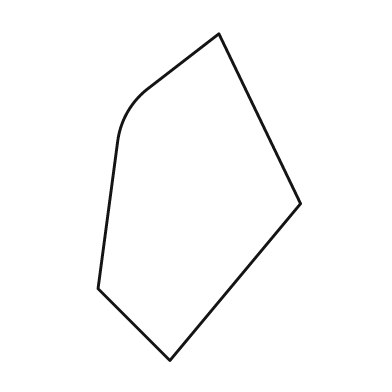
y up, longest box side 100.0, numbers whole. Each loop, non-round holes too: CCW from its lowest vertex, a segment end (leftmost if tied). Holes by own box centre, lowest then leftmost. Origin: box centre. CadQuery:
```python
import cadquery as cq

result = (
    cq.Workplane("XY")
    .moveTo(-9.0, -50.0)
    .lineTo(31.0, -2.0)
    .lineTo(6.0, 50.0)
    .lineTo(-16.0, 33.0)
    .threePointArc((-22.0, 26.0), (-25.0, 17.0))
    .lineTo(-31.0, -28.0)
    .close()
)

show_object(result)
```